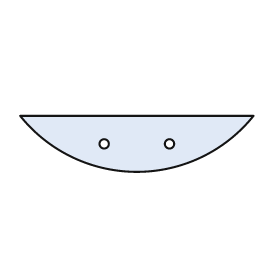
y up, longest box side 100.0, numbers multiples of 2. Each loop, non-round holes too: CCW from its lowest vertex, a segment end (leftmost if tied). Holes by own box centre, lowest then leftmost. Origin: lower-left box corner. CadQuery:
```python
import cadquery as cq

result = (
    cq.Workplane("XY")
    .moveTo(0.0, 24.0)
    .threePointArc((50.0, 0.0), (100.0, 24.0))
    .close()
    .moveTo(36.0, 12.0)
    .circle(2.0)
    .moveTo(64.0, 12.0)
    .circle(2.0)
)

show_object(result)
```